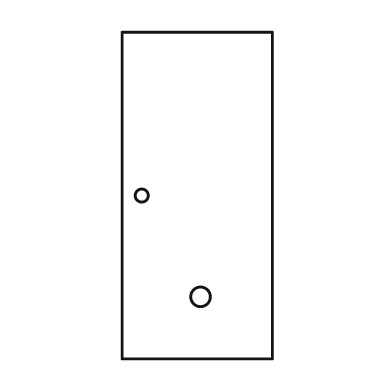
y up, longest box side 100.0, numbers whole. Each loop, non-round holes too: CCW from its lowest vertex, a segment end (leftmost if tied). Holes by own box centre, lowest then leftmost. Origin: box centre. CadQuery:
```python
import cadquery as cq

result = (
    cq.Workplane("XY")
    .moveTo(-23.0, -50.0)
    .lineTo(23.0, -50.0)
    .lineTo(23.0, 50.0)
    .lineTo(-23.0, 50.0)
    .close()
    .moveTo(1.0, -31.0)
    .circle(3.0)
    .moveTo(-17.0, 0.0)
    .circle(2.0)
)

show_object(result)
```